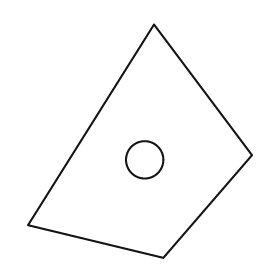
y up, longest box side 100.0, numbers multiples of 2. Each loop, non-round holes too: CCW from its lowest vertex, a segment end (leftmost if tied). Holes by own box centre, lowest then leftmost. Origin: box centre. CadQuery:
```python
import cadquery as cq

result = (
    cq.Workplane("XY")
    .moveTo(10.0, -50.0)
    .lineTo(48.0, -6.0)
    .lineTo(6.0, 50.0)
    .lineTo(-48.0, -36.0)
    .close()
    .moveTo(2.0, -8.0)
    .circle(8.0)
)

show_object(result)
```